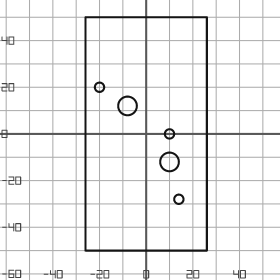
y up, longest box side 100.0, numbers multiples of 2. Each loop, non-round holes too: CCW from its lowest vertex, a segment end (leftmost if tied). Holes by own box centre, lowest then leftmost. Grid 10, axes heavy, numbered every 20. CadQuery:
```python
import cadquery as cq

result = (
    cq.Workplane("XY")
    .moveTo(-26.0, -50.0)
    .lineTo(26.0, -50.0)
    .lineTo(26.0, 50.0)
    .lineTo(-26.0, 50.0)
    .close()
    .moveTo(14.0, -28.0)
    .circle(2.0)
    .moveTo(10.0, -12.0)
    .circle(4.0)
    .moveTo(10.0, 0.0)
    .circle(2.0)
    .moveTo(-8.0, 12.0)
    .circle(4.0)
    .moveTo(-20.0, 20.0)
    .circle(2.0)
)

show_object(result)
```